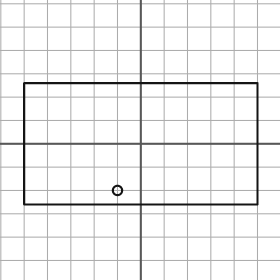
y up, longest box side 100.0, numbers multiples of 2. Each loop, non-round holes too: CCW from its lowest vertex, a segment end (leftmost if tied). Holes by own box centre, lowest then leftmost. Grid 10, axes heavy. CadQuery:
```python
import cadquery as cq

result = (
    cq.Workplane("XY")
    .moveTo(-50.0, -26.0)
    .lineTo(50.0, -26.0)
    .lineTo(50.0, 26.0)
    .lineTo(-50.0, 26.0)
    .close()
    .moveTo(-10.0, -20.0)
    .circle(2.0)
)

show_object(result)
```